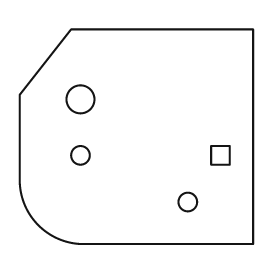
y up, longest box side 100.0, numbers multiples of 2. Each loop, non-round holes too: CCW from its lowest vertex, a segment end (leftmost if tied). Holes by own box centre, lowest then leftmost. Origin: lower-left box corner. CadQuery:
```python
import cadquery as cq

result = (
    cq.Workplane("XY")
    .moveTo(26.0, 0.0)
    .lineTo(100.0, 0.0)
    .lineTo(100.0, 92.0)
    .lineTo(22.0, 92.0)
    .lineTo(0.0, 64.0)
    .lineTo(0.0, 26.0)
    .threePointArc((8.0, 8.0), (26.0, 0.0))
    .close()
    .moveTo(72.0, 18.0)
    .circle(4.0)
    .moveTo(26.0, 38.0)
    .circle(4.0)
    .moveTo(82.0, 34.0)
    .lineTo(90.0, 34.0)
    .lineTo(90.0, 42.0)
    .lineTo(82.0, 42.0)
    .close()
    .moveTo(26.0, 62.0)
    .circle(6.0)
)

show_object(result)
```